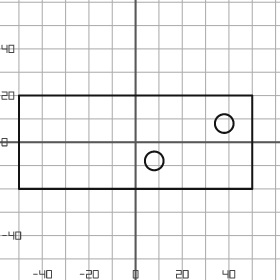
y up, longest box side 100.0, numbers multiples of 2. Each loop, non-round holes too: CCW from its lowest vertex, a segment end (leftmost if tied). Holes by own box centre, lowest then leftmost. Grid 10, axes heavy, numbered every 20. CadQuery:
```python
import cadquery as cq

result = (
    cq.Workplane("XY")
    .moveTo(-50.0, -20.0)
    .lineTo(50.0, -20.0)
    .lineTo(50.0, 20.0)
    .lineTo(-50.0, 20.0)
    .close()
    .moveTo(8.0, -8.0)
    .circle(4.0)
    .moveTo(38.0, 8.0)
    .circle(4.0)
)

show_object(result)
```